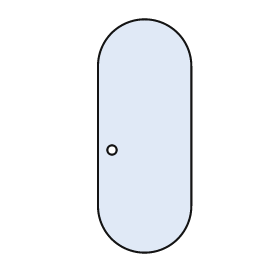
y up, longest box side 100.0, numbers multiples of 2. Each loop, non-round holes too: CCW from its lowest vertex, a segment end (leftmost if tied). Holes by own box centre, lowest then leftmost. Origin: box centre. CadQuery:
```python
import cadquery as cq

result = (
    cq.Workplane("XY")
    .moveTo(-20.0, -30.0)
    .threePointArc((0.0, -50.0), (20.0, -30.0))
    .lineTo(20.0, 30.0)
    .threePointArc((0.0, 50.0), (-20.0, 30.0))
    .close()
    .moveTo(-14.0, -6.0)
    .circle(2.0)
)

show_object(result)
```